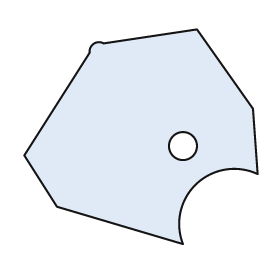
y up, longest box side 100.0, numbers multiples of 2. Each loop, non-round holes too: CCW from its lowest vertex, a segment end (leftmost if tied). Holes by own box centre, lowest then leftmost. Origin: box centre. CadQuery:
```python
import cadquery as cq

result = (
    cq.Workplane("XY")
    .moveTo(18.0, -46.0)
    .threePointArc((24.0, -20.0), (50.0, -16.0))
    .lineTo(48.0, 12.0)
    .lineTo(24.0, 46.0)
    .lineTo(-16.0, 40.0)
    .threePointArc((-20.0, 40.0), (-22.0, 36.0))
    .lineTo(-50.0, -8.0)
    .lineTo(-36.0, -30.0)
    .close()
    .moveTo(18.0, -4.0)
    .circle(6.0)
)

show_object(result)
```